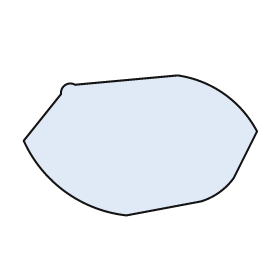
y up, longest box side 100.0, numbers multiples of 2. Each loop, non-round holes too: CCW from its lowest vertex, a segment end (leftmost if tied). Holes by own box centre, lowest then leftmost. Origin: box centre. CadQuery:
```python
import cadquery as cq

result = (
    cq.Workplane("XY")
    .moveTo(-6.0, -30.0)
    .lineTo(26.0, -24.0)
    .threePointArc((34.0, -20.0), (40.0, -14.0))
    .lineTo(50.0, 6.0)
    .threePointArc((36.0, 22.0), (16.0, 30.0))
    .lineTo(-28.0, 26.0)
    .threePointArc((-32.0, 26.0), (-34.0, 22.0))
    .lineTo(-50.0, 2.0)
    .threePointArc((-32.0, -20.0), (-6.0, -30.0))
    .close()
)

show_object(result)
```